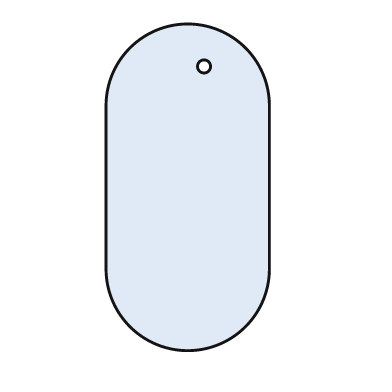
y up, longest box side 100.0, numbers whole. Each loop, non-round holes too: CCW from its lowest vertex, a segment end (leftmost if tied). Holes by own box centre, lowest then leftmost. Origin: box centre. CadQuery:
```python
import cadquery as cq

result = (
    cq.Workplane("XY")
    .moveTo(-25.0, -25.0)
    .threePointArc((0.0, -50.0), (25.0, -25.0))
    .lineTo(25.0, 25.0)
    .threePointArc((0.0, 50.0), (-25.0, 25.0))
    .close()
    .moveTo(5.0, 37.0)
    .circle(2.0)
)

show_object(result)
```